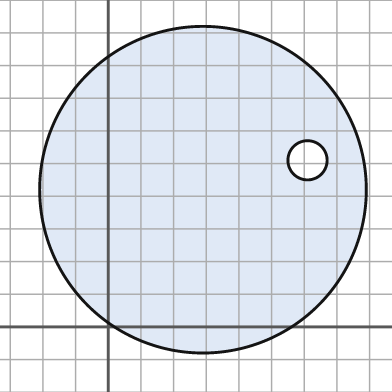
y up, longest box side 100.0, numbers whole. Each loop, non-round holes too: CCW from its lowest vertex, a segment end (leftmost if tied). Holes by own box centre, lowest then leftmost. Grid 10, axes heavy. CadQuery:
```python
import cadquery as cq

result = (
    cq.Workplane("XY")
    .moveTo(29.0, 42.0)
    .circle(50.0)
    .moveTo(61.0, 51.0)
    .circle(6.0)
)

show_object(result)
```